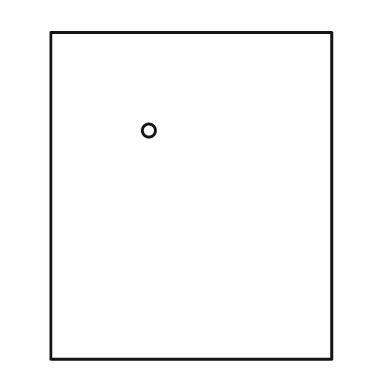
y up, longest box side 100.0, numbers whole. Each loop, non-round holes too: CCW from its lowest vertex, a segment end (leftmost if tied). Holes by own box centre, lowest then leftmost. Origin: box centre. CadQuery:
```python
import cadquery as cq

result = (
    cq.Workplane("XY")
    .moveTo(-43.0, -50.0)
    .lineTo(43.0, -50.0)
    .lineTo(43.0, 50.0)
    .lineTo(-43.0, 50.0)
    .close()
    .moveTo(-13.0, 20.0)
    .circle(2.0)
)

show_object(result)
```